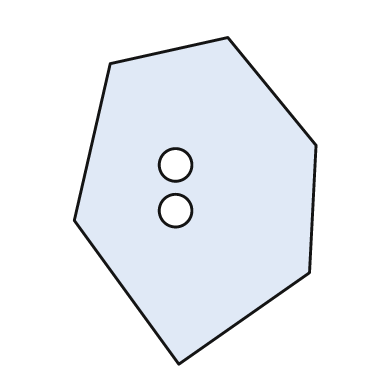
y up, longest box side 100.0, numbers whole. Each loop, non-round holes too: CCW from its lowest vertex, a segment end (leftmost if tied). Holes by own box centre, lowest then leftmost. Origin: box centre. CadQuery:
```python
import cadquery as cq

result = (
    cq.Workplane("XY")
    .moveTo(-5.0, -50.0)
    .lineTo(35.0, -22.0)
    .lineTo(37.0, 17.0)
    .lineTo(10.0, 50.0)
    .lineTo(-26.0, 42.0)
    .lineTo(-37.0, -6.0)
    .close()
    .moveTo(-6.0, -3.0)
    .circle(5.0)
    .moveTo(-6.0, 11.0)
    .circle(5.0)
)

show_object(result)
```